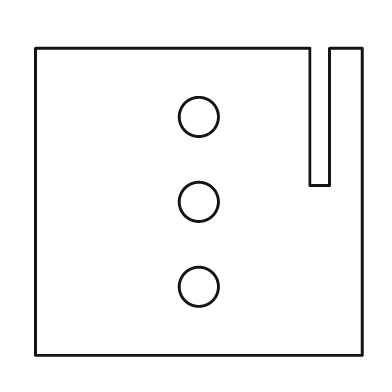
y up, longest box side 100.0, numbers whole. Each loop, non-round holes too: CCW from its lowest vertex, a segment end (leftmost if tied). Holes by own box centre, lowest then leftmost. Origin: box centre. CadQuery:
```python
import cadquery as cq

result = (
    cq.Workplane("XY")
    .moveTo(-50.0, -47.0)
    .lineTo(50.0, -47.0)
    .lineTo(50.0, 47.0)
    .lineTo(40.0, 47.0)
    .lineTo(40.0, 5.0)
    .lineTo(34.0, 5.0)
    .lineTo(34.0, 47.0)
    .lineTo(-50.0, 47.0)
    .close()
    .moveTo(0.0, -26.0)
    .circle(6.0)
    .moveTo(0.0, 0.0)
    .circle(6.0)
    .moveTo(0.0, 26.0)
    .circle(6.0)
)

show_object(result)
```